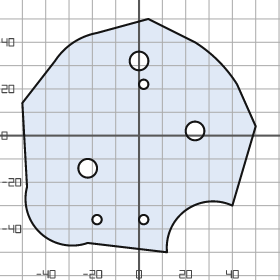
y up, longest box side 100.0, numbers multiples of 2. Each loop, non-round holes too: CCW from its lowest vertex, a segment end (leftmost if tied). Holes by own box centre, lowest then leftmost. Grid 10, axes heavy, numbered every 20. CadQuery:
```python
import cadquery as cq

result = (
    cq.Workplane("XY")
    .moveTo(12.0, -50.0)
    .threePointArc((20.0, -32.0), (40.0, -30.0))
    .lineTo(50.0, 4.0)
    .lineTo(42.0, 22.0)
    .threePointArc((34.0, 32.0), (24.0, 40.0))
    .lineTo(4.0, 50.0)
    .lineTo(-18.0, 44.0)
    .threePointArc((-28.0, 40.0), (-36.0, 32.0))
    .lineTo(-50.0, 14.0)
    .lineTo(-48.0, -22.0)
    .threePointArc((-42.0, -42.0), (-22.0, -46.0))
    .close()
    .moveTo(-18.0, -36.0)
    .circle(2.0)
    .moveTo(2.0, -36.0)
    .circle(2.0)
    .moveTo(-22.0, -14.0)
    .circle(4.0)
    .moveTo(24.0, 2.0)
    .circle(4.0)
    .moveTo(2.0, 22.0)
    .circle(2.0)
    .moveTo(0.0, 32.0)
    .circle(4.0)
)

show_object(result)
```